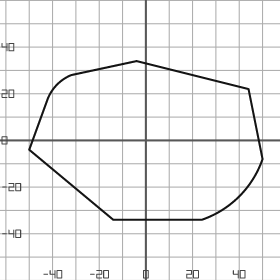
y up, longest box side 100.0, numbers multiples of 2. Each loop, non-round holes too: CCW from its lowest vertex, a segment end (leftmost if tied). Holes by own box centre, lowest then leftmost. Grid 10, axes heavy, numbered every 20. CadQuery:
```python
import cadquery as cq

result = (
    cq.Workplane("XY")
    .moveTo(-14.0, -34.0)
    .lineTo(24.0, -34.0)
    .threePointArc((40.0, -24.0), (50.0, -8.0))
    .lineTo(44.0, 22.0)
    .lineTo(-4.0, 34.0)
    .lineTo(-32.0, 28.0)
    .threePointArc((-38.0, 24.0), (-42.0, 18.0))
    .lineTo(-50.0, -4.0)
    .close()
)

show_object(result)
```